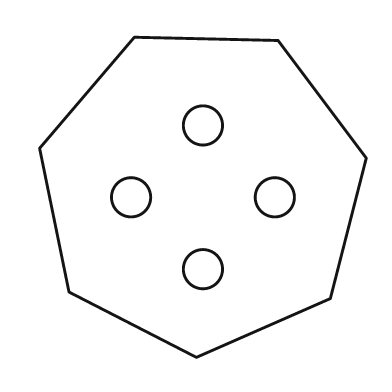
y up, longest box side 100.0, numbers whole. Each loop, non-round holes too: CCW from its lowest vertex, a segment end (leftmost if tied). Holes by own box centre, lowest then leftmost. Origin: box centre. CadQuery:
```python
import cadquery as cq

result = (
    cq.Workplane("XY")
    .moveTo(-2.0, -49.0)
    .lineTo(39.0, -31.0)
    .lineTo(50.0, 12.0)
    .lineTo(23.0, 48.0)
    .lineTo(-21.0, 49.0)
    .lineTo(-50.0, 15.0)
    .lineTo(-41.0, -29.0)
    .close()
    .moveTo(0.0, -22.0)
    .circle(6.0)
    .moveTo(-22.0, 0.0)
    .circle(6.0)
    .moveTo(22.0, 0.0)
    .circle(6.0)
    .moveTo(0.0, 22.0)
    .circle(6.0)
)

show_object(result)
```